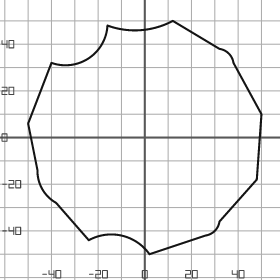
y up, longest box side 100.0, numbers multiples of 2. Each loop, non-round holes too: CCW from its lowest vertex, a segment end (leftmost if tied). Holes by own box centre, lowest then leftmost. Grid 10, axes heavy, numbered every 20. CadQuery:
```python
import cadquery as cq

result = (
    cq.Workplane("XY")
    .moveTo(2.0, -50.0)
    .lineTo(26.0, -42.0)
    .threePointArc((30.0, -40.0), (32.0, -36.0))
    .lineTo(48.0, -18.0)
    .lineTo(50.0, 10.0)
    .lineTo(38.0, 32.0)
    .threePointArc((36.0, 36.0), (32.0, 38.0))
    .lineTo(12.0, 50.0)
    .threePointArc((-2.0, 46.0), (-16.0, 48.0))
    .threePointArc((-24.0, 34.0), (-40.0, 32.0))
    .lineTo(-50.0, 6.0)
    .lineTo(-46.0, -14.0)
    .threePointArc((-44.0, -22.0), (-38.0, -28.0))
    .lineTo(-24.0, -44.0)
    .threePointArc((-10.0, -42.0), (2.0, -50.0))
    .close()
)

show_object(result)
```